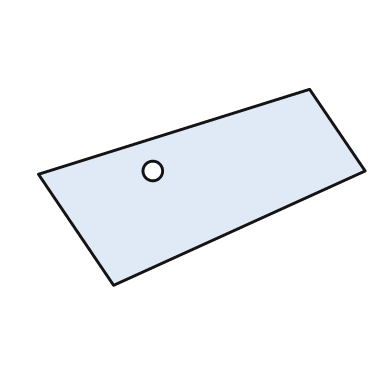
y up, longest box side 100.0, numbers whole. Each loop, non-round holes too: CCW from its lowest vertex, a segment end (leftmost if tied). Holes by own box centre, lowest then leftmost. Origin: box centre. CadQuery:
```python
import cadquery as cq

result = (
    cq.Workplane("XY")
    .moveTo(-27.0, -30.0)
    .lineTo(50.0, 5.0)
    .lineTo(33.0, 30.0)
    .lineTo(-50.0, 4.0)
    .close()
    .moveTo(-15.0, 5.0)
    .circle(3.0)
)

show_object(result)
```